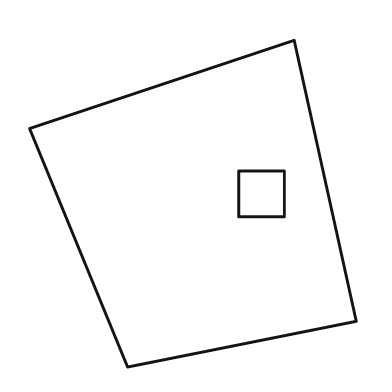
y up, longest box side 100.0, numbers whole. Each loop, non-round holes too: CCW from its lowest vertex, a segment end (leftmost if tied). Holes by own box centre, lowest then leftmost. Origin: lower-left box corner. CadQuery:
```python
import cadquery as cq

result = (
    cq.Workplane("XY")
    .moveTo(30.0, 0.0)
    .lineTo(100.0, 14.0)
    .lineTo(81.0, 100.0)
    .lineTo(0.0, 73.0)
    .close()
    .moveTo(64.0, 46.0)
    .lineTo(78.0, 46.0)
    .lineTo(78.0, 60.0)
    .lineTo(64.0, 60.0)
    .close()
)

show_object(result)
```